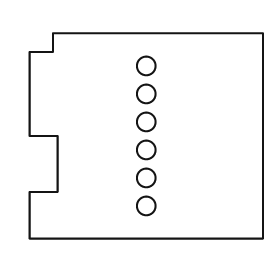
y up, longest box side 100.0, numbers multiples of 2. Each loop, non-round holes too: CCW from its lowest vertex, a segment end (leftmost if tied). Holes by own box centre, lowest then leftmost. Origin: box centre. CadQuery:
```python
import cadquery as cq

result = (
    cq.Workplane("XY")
    .moveTo(-50.0, -44.0)
    .lineTo(50.0, -44.0)
    .lineTo(50.0, 44.0)
    .lineTo(-40.0, 44.0)
    .lineTo(-40.0, 36.0)
    .lineTo(-50.0, 36.0)
    .lineTo(-50.0, 0.0)
    .lineTo(-38.0, 0.0)
    .lineTo(-38.0, -24.0)
    .lineTo(-50.0, -24.0)
    .close()
    .moveTo(0.0, -30.0)
    .circle(4.0)
    .moveTo(0.0, -18.0)
    .circle(4.0)
    .moveTo(0.0, -6.0)
    .circle(4.0)
    .moveTo(0.0, 6.0)
    .circle(4.0)
    .moveTo(0.0, 18.0)
    .circle(4.0)
    .moveTo(0.0, 30.0)
    .circle(4.0)
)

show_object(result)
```